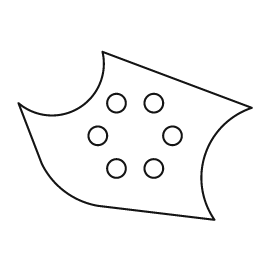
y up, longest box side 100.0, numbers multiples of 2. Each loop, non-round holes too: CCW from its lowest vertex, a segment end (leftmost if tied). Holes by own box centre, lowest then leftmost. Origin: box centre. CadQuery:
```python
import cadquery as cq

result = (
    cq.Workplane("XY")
    .moveTo(34.0, -36.0)
    .threePointArc((30.0, -8.0), (50.0, 12.0))
    .lineTo(-14.0, 36.0)
    .threePointArc((-24.0, 12.0), (-50.0, 14.0))
    .lineTo(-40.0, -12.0)
    .threePointArc((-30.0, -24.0), (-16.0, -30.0))
    .close()
    .moveTo(-8.0, -14.0)
    .circle(4.0)
    .moveTo(8.0, -14.0)
    .circle(4.0)
    .moveTo(-16.0, 0.0)
    .circle(4.0)
    .moveTo(16.0, 0.0)
    .circle(4.0)
    .moveTo(-8.0, 14.0)
    .circle(4.0)
    .moveTo(8.0, 14.0)
    .circle(4.0)
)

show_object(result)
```